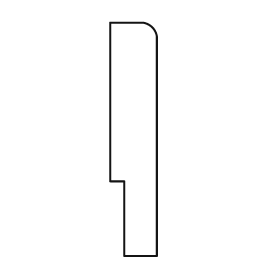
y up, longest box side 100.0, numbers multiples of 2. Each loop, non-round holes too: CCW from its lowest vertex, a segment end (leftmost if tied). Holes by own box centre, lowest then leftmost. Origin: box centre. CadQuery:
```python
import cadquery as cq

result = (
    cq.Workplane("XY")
    .moveTo(-4.0, -50.0)
    .lineTo(10.0, -50.0)
    .lineTo(10.0, 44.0)
    .threePointArc((8.0, 48.0), (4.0, 50.0))
    .lineTo(-10.0, 50.0)
    .lineTo(-10.0, -18.0)
    .lineTo(-4.0, -18.0)
    .close()
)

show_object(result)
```